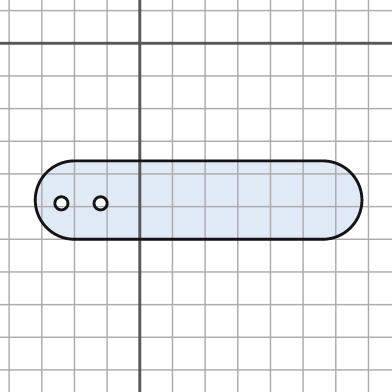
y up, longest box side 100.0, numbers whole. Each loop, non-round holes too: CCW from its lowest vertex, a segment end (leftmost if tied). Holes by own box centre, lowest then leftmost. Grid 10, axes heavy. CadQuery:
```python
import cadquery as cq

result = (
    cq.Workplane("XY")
    .moveTo(-20.0, -60.0)
    .lineTo(56.0, -60.0)
    .threePointArc((68.0, -48.0), (56.0, -36.0))
    .lineTo(-20.0, -36.0)
    .threePointArc((-32.0, -48.0), (-20.0, -60.0))
    .close()
    .moveTo(-24.0, -49.0)
    .circle(2.0)
    .moveTo(-12.0, -49.0)
    .circle(2.0)
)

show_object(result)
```